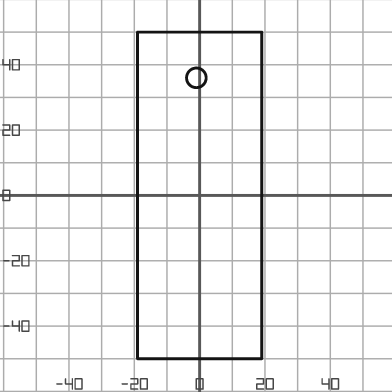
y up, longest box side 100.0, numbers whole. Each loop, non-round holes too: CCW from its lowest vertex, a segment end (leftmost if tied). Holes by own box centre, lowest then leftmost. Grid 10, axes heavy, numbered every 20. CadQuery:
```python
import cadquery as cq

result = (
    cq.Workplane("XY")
    .moveTo(-19.0, -50.0)
    .lineTo(19.0, -50.0)
    .lineTo(19.0, 50.0)
    .lineTo(-19.0, 50.0)
    .close()
    .moveTo(-1.0, 36.0)
    .circle(3.0)
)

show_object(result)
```